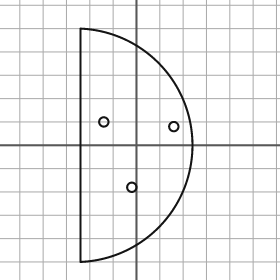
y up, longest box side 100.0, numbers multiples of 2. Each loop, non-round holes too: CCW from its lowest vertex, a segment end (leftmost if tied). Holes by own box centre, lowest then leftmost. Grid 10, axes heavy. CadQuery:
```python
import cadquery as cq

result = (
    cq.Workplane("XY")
    .moveTo(-24.0, -50.0)
    .threePointArc((24.0, 0.0), (-24.0, 50.0))
    .close()
    .moveTo(-2.0, -18.0)
    .circle(2.0)
    .moveTo(16.0, 8.0)
    .circle(2.0)
    .moveTo(-14.0, 10.0)
    .circle(2.0)
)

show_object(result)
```